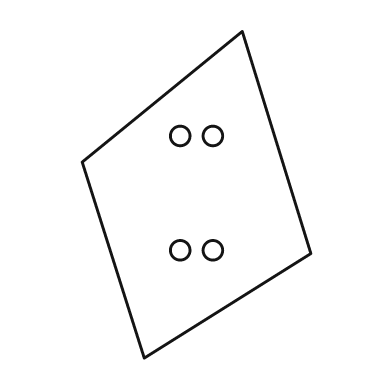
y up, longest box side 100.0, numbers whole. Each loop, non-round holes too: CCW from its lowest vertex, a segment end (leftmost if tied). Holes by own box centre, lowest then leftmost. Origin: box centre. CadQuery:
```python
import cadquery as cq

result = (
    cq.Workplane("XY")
    .moveTo(-16.0, -50.0)
    .lineTo(35.0, -18.0)
    .lineTo(14.0, 50.0)
    .lineTo(-35.0, 10.0)
    .close()
    .moveTo(-5.0, -17.0)
    .circle(3.0)
    .moveTo(5.0, -17.0)
    .circle(3.0)
    .moveTo(-5.0, 18.0)
    .circle(3.0)
    .moveTo(5.0, 18.0)
    .circle(3.0)
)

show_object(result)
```